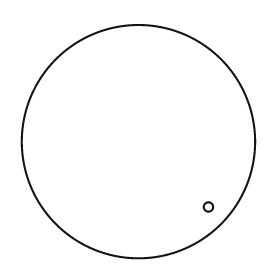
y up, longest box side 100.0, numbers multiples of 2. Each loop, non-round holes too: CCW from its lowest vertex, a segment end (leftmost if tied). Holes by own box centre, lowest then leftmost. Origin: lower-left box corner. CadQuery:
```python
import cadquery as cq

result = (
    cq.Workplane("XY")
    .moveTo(50.0, 50.0)
    .circle(50.0)
    .moveTo(80.0, 22.0)
    .circle(2.0)
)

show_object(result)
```